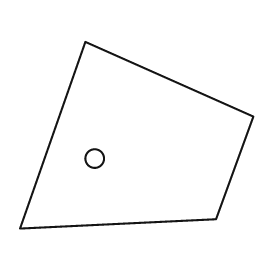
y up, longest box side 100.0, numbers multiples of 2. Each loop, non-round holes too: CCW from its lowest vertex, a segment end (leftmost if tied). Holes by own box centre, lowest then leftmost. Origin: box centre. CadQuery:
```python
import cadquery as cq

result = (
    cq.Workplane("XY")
    .moveTo(-50.0, -40.0)
    .lineTo(34.0, -36.0)
    .lineTo(50.0, 8.0)
    .lineTo(-22.0, 40.0)
    .close()
    .moveTo(-18.0, -10.0)
    .circle(4.0)
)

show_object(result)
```